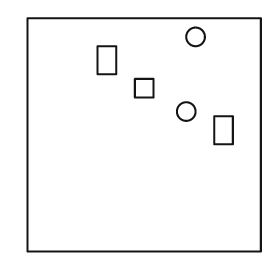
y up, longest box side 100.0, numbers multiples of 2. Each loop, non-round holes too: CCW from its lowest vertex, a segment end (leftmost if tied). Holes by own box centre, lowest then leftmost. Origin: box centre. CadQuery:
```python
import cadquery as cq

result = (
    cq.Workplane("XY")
    .moveTo(-50.0, -50.0)
    .lineTo(50.0, -50.0)
    .lineTo(50.0, 50.0)
    .lineTo(-50.0, 50.0)
    .close()
    .moveTo(30.0, -4.0)
    .lineTo(38.0, -4.0)
    .lineTo(38.0, 8.0)
    .lineTo(30.0, 8.0)
    .close()
    .moveTo(18.0, 10.0)
    .circle(4.0)
    .moveTo(-4.0, 16.0)
    .lineTo(4.0, 16.0)
    .lineTo(4.0, 24.0)
    .lineTo(-4.0, 24.0)
    .close()
    .moveTo(-20.0, 26.0)
    .lineTo(-12.0, 26.0)
    .lineTo(-12.0, 38.0)
    .lineTo(-20.0, 38.0)
    .close()
    .moveTo(22.0, 42.0)
    .circle(4.0)
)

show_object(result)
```